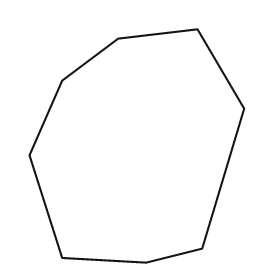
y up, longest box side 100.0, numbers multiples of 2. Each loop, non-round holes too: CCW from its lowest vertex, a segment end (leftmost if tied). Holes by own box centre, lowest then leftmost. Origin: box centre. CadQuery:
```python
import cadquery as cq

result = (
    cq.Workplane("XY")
    .moveTo(4.0, -50.0)
    .lineTo(28.0, -44.0)
    .lineTo(46.0, 16.0)
    .lineTo(26.0, 50.0)
    .lineTo(-8.0, 46.0)
    .lineTo(-32.0, 28.0)
    .lineTo(-46.0, -4.0)
    .lineTo(-32.0, -48.0)
    .close()
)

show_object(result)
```